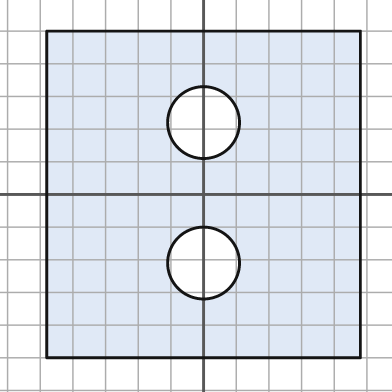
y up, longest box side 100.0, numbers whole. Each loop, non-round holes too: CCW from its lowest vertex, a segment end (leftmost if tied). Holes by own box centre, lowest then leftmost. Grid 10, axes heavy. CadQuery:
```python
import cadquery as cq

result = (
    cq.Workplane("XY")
    .moveTo(-48.0, -50.0)
    .lineTo(48.0, -50.0)
    .lineTo(48.0, 50.0)
    .lineTo(-48.0, 50.0)
    .close()
    .moveTo(0.0, -21.0)
    .circle(11.0)
    .moveTo(0.0, 22.0)
    .circle(11.0)
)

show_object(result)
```